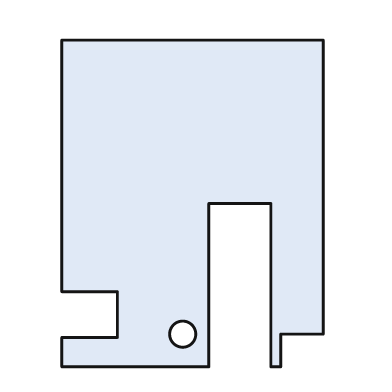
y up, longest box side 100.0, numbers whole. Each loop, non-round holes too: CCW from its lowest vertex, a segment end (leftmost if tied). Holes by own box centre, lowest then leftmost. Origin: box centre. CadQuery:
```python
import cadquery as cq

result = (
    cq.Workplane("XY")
    .moveTo(-40.0, -50.0)
    .lineTo(5.0, -50.0)
    .lineTo(5.0, 0.0)
    .lineTo(24.0, 0.0)
    .lineTo(24.0, -50.0)
    .lineTo(27.0, -50.0)
    .lineTo(27.0, -40.0)
    .lineTo(40.0, -40.0)
    .lineTo(40.0, 50.0)
    .lineTo(-40.0, 50.0)
    .lineTo(-40.0, -27.0)
    .lineTo(-23.0, -27.0)
    .lineTo(-23.0, -41.0)
    .lineTo(-40.0, -41.0)
    .close()
    .moveTo(-3.0, -40.0)
    .circle(4.0)
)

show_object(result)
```